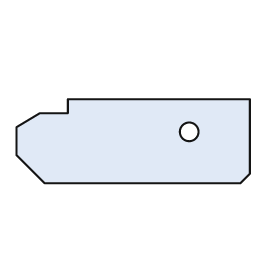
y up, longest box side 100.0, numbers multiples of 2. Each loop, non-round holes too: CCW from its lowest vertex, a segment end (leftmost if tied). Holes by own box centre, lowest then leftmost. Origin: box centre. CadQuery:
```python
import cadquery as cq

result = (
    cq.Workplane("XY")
    .moveTo(-38.0, -18.0)
    .lineTo(46.0, -18.0)
    .lineTo(50.0, -14.0)
    .lineTo(50.0, 18.0)
    .lineTo(-28.0, 18.0)
    .lineTo(-28.0, 12.0)
    .lineTo(-40.0, 12.0)
    .lineTo(-50.0, 6.0)
    .lineTo(-50.0, -6.0)
    .close()
    .moveTo(24.0, 4.0)
    .circle(4.0)
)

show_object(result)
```